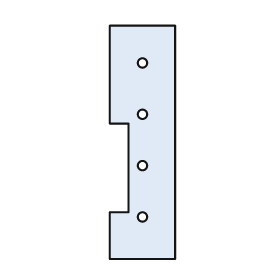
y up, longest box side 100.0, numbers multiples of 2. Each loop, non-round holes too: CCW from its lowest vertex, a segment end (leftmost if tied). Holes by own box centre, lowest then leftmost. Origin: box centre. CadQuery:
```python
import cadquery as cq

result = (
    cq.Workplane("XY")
    .moveTo(-14.0, -50.0)
    .lineTo(14.0, -50.0)
    .lineTo(14.0, 50.0)
    .lineTo(-14.0, 50.0)
    .lineTo(-14.0, 8.0)
    .lineTo(-6.0, 8.0)
    .lineTo(-6.0, -30.0)
    .lineTo(-14.0, -30.0)
    .close()
    .moveTo(0.0, -32.0)
    .circle(2.0)
    .moveTo(0.0, -10.0)
    .circle(2.0)
    .moveTo(0.0, 12.0)
    .circle(2.0)
    .moveTo(0.0, 34.0)
    .circle(2.0)
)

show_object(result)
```